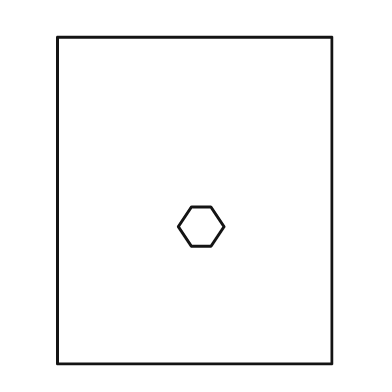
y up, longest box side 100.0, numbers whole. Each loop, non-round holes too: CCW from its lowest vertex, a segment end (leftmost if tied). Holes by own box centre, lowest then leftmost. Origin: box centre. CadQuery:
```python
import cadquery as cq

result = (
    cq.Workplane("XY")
    .moveTo(-42.0, -50.0)
    .lineTo(42.0, -50.0)
    .lineTo(42.0, 50.0)
    .lineTo(-42.0, 50.0)
    .close()
    .moveTo(-1.0, -14.0)
    .lineTo(5.0, -14.0)
    .lineTo(9.0, -8.0)
    .lineTo(5.0, -2.0)
    .lineTo(-1.0, -2.0)
    .lineTo(-5.0, -8.0)
    .close()
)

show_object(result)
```